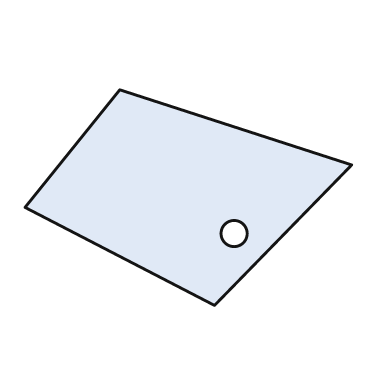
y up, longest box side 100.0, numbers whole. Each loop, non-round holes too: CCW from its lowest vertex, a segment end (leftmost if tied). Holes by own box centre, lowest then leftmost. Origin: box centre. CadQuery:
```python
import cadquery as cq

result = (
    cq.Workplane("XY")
    .moveTo(8.0, -33.0)
    .lineTo(50.0, 10.0)
    .lineTo(-21.0, 33.0)
    .lineTo(-50.0, -3.0)
    .close()
    .moveTo(14.0, -11.0)
    .circle(4.0)
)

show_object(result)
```